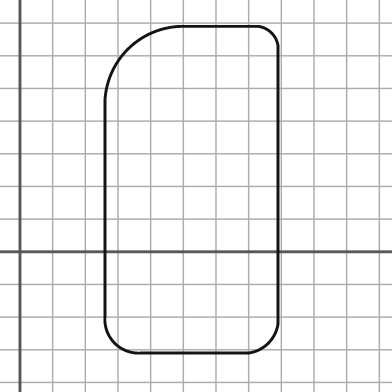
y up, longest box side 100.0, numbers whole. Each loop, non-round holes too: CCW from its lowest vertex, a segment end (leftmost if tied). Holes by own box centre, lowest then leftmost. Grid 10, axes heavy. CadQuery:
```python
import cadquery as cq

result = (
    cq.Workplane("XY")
    .moveTo(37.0, -31.0)
    .lineTo(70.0, -31.0)
    .threePointArc((76.0, -28.0), (79.0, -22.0))
    .lineTo(79.0, 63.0)
    .threePointArc((77.0, 67.0), (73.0, 69.0))
    .lineTo(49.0, 69.0)
    .threePointArc((33.0, 62.0), (26.0, 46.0))
    .lineTo(26.0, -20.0)
    .threePointArc((29.0, -28.0), (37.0, -31.0))
    .close()
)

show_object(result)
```